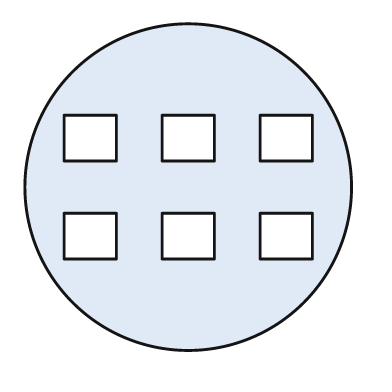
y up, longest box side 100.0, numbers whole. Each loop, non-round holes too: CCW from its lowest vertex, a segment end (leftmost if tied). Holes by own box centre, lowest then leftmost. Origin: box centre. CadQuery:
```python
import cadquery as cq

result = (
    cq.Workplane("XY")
    .moveTo(0.0, 0.0)
    .circle(50.0)
    .moveTo(-38.0, -22.0)
    .lineTo(-22.0, -22.0)
    .lineTo(-22.0, -8.0)
    .lineTo(-38.0, -8.0)
    .close()
    .moveTo(-8.0, -22.0)
    .lineTo(8.0, -22.0)
    .lineTo(8.0, -8.0)
    .lineTo(-8.0, -8.0)
    .close()
    .moveTo(22.0, -22.0)
    .lineTo(38.0, -22.0)
    .lineTo(38.0, -8.0)
    .lineTo(22.0, -8.0)
    .close()
    .moveTo(-38.0, 8.0)
    .lineTo(-22.0, 8.0)
    .lineTo(-22.0, 22.0)
    .lineTo(-38.0, 22.0)
    .close()
    .moveTo(-8.0, 8.0)
    .lineTo(8.0, 8.0)
    .lineTo(8.0, 22.0)
    .lineTo(-8.0, 22.0)
    .close()
    .moveTo(22.0, 8.0)
    .lineTo(38.0, 8.0)
    .lineTo(38.0, 22.0)
    .lineTo(22.0, 22.0)
    .close()
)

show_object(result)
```